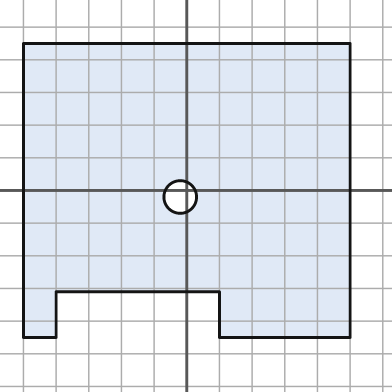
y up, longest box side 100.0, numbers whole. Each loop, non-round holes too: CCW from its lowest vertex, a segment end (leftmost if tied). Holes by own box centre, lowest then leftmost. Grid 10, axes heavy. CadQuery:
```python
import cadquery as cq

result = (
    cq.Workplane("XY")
    .moveTo(-50.0, -45.0)
    .lineTo(-40.0, -45.0)
    .lineTo(-40.0, -31.0)
    .lineTo(10.0, -31.0)
    .lineTo(10.0, -45.0)
    .lineTo(50.0, -45.0)
    .lineTo(50.0, 45.0)
    .lineTo(-50.0, 45.0)
    .close()
    .moveTo(-2.0, -2.0)
    .circle(5.0)
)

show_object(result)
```